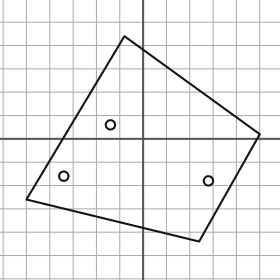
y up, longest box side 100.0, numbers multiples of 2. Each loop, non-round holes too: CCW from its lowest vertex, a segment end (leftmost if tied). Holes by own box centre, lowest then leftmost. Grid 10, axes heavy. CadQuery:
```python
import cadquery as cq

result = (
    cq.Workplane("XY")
    .moveTo(24.0, -44.0)
    .lineTo(50.0, 2.0)
    .lineTo(-8.0, 44.0)
    .lineTo(-50.0, -26.0)
    .close()
    .moveTo(28.0, -18.0)
    .circle(2.0)
    .moveTo(-34.0, -16.0)
    .circle(2.0)
    .moveTo(-14.0, 6.0)
    .circle(2.0)
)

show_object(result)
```